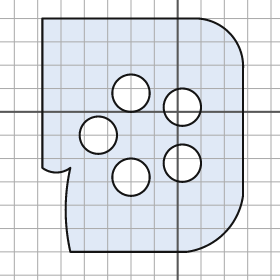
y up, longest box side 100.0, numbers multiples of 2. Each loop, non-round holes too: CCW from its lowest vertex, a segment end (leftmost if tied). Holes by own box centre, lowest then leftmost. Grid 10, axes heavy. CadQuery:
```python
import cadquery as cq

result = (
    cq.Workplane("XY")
    .moveTo(-46.0, -60.0)
    .lineTo(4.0, -60.0)
    .threePointArc((20.0, -52.0), (28.0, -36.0))
    .lineTo(28.0, 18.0)
    .threePointArc((22.0, 34.0), (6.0, 40.0))
    .lineTo(-58.0, 40.0)
    .lineTo(-58.0, -24.0)
    .threePointArc((-52.0, -26.0), (-46.0, -24.0))
    .threePointArc((-48.0, -42.0), (-46.0, -60.0))
    .close()
    .moveTo(-20.0, -28.0)
    .circle(8.0)
    .moveTo(2.0, -22.0)
    .circle(8.0)
    .moveTo(-34.0, -10.0)
    .circle(8.0)
    .moveTo(2.0, 2.0)
    .circle(8.0)
    .moveTo(-20.0, 8.0)
    .circle(8.0)
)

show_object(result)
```